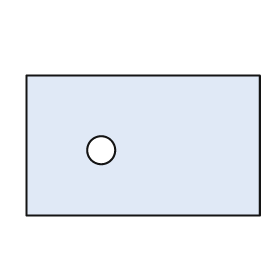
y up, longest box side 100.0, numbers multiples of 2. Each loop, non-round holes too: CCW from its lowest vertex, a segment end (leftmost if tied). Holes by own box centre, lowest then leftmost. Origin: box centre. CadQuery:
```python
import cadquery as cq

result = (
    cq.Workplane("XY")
    .moveTo(-50.0, -30.0)
    .lineTo(50.0, -30.0)
    .lineTo(50.0, 30.0)
    .lineTo(-50.0, 30.0)
    .close()
    .moveTo(-18.0, -2.0)
    .circle(6.0)
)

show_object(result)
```